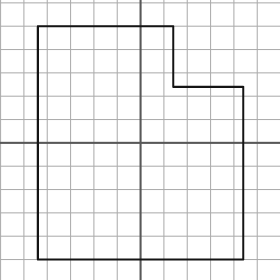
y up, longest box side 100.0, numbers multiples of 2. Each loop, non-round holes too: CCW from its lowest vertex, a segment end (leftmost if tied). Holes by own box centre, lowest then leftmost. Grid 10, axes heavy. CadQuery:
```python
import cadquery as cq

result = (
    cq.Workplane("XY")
    .moveTo(-44.0, -50.0)
    .lineTo(44.0, -50.0)
    .lineTo(44.0, 24.0)
    .lineTo(14.0, 24.0)
    .lineTo(14.0, 50.0)
    .lineTo(-44.0, 50.0)
    .close()
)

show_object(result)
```